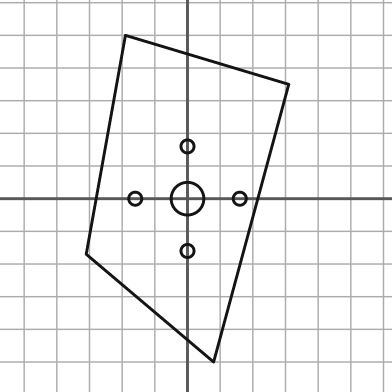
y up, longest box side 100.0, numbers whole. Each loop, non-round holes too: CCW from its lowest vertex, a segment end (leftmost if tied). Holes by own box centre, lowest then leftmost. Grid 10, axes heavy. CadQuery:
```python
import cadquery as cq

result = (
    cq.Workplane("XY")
    .moveTo(8.0, -50.0)
    .lineTo(31.0, 35.0)
    .lineTo(-19.0, 50.0)
    .lineTo(-31.0, -17.0)
    .close()
    .moveTo(0.0, -16.0)
    .circle(2.0)
    .moveTo(-16.0, 0.0)
    .circle(2.0)
    .moveTo(0.0, 0.0)
    .circle(5.0)
    .moveTo(16.0, 0.0)
    .circle(2.0)
    .moveTo(0.0, 16.0)
    .circle(2.0)
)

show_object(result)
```